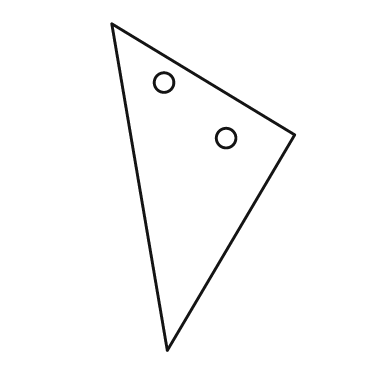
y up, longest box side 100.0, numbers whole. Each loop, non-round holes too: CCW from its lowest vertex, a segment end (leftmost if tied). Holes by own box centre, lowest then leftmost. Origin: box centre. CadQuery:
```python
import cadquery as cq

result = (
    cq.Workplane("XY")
    .moveTo(-11.0, -50.0)
    .lineTo(28.0, 16.0)
    .lineTo(-28.0, 50.0)
    .close()
    .moveTo(7.0, 15.0)
    .circle(3.0)
    .moveTo(-12.0, 32.0)
    .circle(3.0)
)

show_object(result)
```